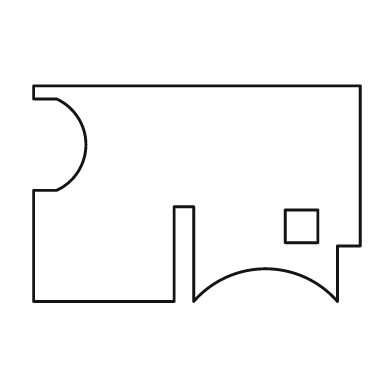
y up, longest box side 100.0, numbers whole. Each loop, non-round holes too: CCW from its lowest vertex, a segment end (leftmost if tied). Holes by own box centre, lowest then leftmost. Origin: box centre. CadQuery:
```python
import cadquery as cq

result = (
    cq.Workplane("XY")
    .moveTo(-50.0, -33.0)
    .lineTo(-7.0, -33.0)
    .lineTo(-7.0, -4.0)
    .lineTo(-1.0, -4.0)
    .lineTo(-1.0, -33.0)
    .threePointArc((21.0, -23.0), (43.0, -33.0))
    .lineTo(43.0, -16.0)
    .lineTo(50.0, -16.0)
    .lineTo(50.0, 33.0)
    .lineTo(-50.0, 33.0)
    .lineTo(-50.0, 29.0)
    .lineTo(-43.0, 29.0)
    .threePointArc((-34.0, 15.0), (-43.0, 1.0))
    .lineTo(-50.0, 1.0)
    .close()
    .moveTo(27.0, -15.0)
    .lineTo(37.0, -15.0)
    .lineTo(37.0, -5.0)
    .lineTo(27.0, -5.0)
    .close()
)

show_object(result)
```